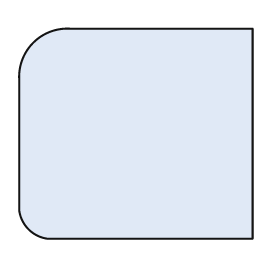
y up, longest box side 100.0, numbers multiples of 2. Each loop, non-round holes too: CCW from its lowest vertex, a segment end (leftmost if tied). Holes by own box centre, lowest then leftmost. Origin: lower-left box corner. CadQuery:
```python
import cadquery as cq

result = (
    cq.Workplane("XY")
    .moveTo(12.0, 0.0)
    .lineTo(100.0, 0.0)
    .lineTo(100.0, 90.0)
    .lineTo(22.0, 90.0)
    .threePointArc((6.0, 84.0), (0.0, 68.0))
    .lineTo(0.0, 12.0)
    .threePointArc((4.0, 4.0), (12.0, 0.0))
    .close()
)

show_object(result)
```